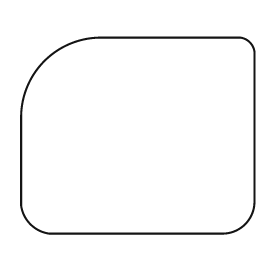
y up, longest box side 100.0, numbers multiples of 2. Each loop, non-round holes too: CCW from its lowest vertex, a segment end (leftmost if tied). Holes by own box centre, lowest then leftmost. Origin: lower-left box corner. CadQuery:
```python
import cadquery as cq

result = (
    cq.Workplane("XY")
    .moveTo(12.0, 0.0)
    .lineTo(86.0, 0.0)
    .threePointArc((96.0, 4.0), (100.0, 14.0))
    .lineTo(100.0, 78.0)
    .threePointArc((98.0, 82.0), (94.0, 84.0))
    .lineTo(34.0, 84.0)
    .threePointArc((10.0, 74.0), (0.0, 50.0))
    .lineTo(0.0, 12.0)
    .threePointArc((4.0, 4.0), (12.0, 0.0))
    .close()
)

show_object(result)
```